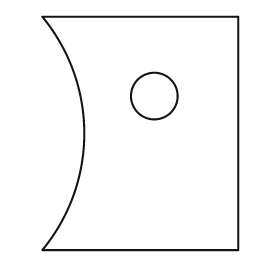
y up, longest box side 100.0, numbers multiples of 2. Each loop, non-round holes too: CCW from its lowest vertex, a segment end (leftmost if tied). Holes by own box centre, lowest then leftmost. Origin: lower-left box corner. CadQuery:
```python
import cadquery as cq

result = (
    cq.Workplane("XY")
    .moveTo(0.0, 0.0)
    .lineTo(84.0, 0.0)
    .lineTo(84.0, 100.0)
    .lineTo(0.0, 100.0)
    .threePointArc((18.0, 50.0), (0.0, 0.0))
    .close()
    .moveTo(48.0, 66.0)
    .circle(10.0)
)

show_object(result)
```